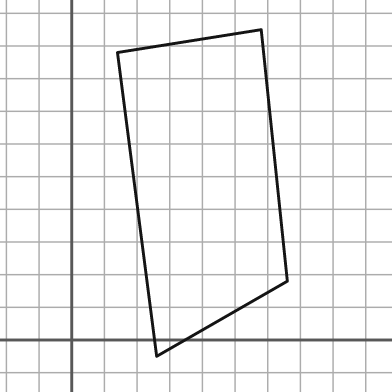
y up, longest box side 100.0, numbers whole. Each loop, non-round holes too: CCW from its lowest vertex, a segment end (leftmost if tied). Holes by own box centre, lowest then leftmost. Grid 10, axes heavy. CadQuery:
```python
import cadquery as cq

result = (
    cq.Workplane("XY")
    .moveTo(26.0, -5.0)
    .lineTo(66.0, 18.0)
    .lineTo(58.0, 95.0)
    .lineTo(14.0, 88.0)
    .close()
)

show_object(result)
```